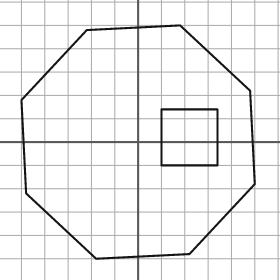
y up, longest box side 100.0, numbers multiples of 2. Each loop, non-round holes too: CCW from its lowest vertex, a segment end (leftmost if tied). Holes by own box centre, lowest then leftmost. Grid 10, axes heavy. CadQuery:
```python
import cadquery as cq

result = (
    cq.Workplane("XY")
    .moveTo(-18.0, -50.0)
    .lineTo(22.0, -48.0)
    .lineTo(50.0, -18.0)
    .lineTo(48.0, 22.0)
    .lineTo(18.0, 50.0)
    .lineTo(-22.0, 48.0)
    .lineTo(-50.0, 18.0)
    .lineTo(-48.0, -22.0)
    .close()
    .moveTo(10.0, -10.0)
    .lineTo(34.0, -10.0)
    .lineTo(34.0, 14.0)
    .lineTo(10.0, 14.0)
    .close()
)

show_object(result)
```